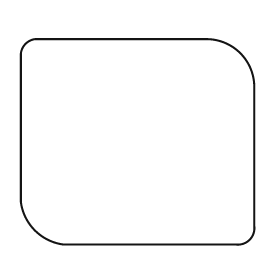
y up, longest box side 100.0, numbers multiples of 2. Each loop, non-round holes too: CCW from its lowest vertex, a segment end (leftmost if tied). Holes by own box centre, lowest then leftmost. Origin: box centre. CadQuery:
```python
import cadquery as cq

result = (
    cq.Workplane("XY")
    .moveTo(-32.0, -44.0)
    .lineTo(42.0, -44.0)
    .threePointArc((48.0, -42.0), (50.0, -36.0))
    .lineTo(50.0, 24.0)
    .threePointArc((44.0, 38.0), (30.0, 44.0))
    .lineTo(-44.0, 44.0)
    .threePointArc((-48.0, 42.0), (-50.0, 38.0))
    .lineTo(-50.0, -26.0)
    .threePointArc((-44.0, -38.0), (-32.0, -44.0))
    .close()
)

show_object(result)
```